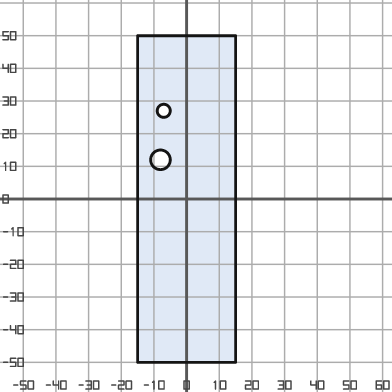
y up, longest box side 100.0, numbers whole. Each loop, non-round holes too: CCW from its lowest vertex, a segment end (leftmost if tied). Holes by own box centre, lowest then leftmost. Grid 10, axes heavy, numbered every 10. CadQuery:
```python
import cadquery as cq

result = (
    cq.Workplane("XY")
    .moveTo(-15.0, -50.0)
    .lineTo(15.0, -50.0)
    .lineTo(15.0, 50.0)
    .lineTo(-15.0, 50.0)
    .close()
    .moveTo(-8.0, 12.0)
    .circle(3.0)
    .moveTo(-7.0, 27.0)
    .circle(2.0)
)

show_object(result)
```